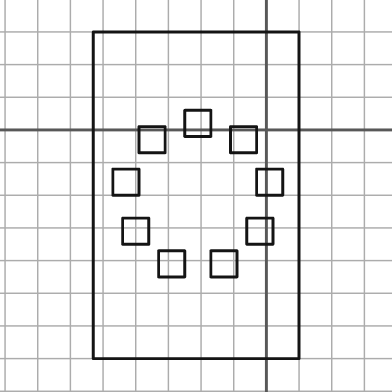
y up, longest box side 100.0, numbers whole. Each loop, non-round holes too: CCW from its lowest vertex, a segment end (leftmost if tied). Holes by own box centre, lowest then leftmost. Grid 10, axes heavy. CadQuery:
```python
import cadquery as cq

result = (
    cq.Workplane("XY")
    .moveTo(-53.0, -70.0)
    .lineTo(10.0, -70.0)
    .lineTo(10.0, 30.0)
    .lineTo(-53.0, 30.0)
    .close()
    .moveTo(-33.0, -45.0)
    .lineTo(-25.0, -45.0)
    .lineTo(-25.0, -37.0)
    .lineTo(-33.0, -37.0)
    .close()
    .moveTo(-17.0, -45.0)
    .lineTo(-9.0, -45.0)
    .lineTo(-9.0, -37.0)
    .lineTo(-17.0, -37.0)
    .close()
    .moveTo(-44.0, -35.0)
    .lineTo(-36.0, -35.0)
    .lineTo(-36.0, -27.0)
    .lineTo(-44.0, -27.0)
    .close()
    .moveTo(-6.0, -35.0)
    .lineTo(2.0, -35.0)
    .lineTo(2.0, -27.0)
    .lineTo(-6.0, -27.0)
    .close()
    .moveTo(-47.0, -20.0)
    .lineTo(-39.0, -20.0)
    .lineTo(-39.0, -12.0)
    .lineTo(-47.0, -12.0)
    .close()
    .moveTo(-3.0, -20.0)
    .lineTo(5.0, -20.0)
    .lineTo(5.0, -12.0)
    .lineTo(-3.0, -12.0)
    .close()
    .moveTo(-39.0, -7.0)
    .lineTo(-31.0, -7.0)
    .lineTo(-31.0, 1.0)
    .lineTo(-39.0, 1.0)
    .close()
    .moveTo(-11.0, -7.0)
    .lineTo(-3.0, -7.0)
    .lineTo(-3.0, 1.0)
    .lineTo(-11.0, 1.0)
    .close()
    .moveTo(-25.0, -2.0)
    .lineTo(-17.0, -2.0)
    .lineTo(-17.0, 6.0)
    .lineTo(-25.0, 6.0)
    .close()
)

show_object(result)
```